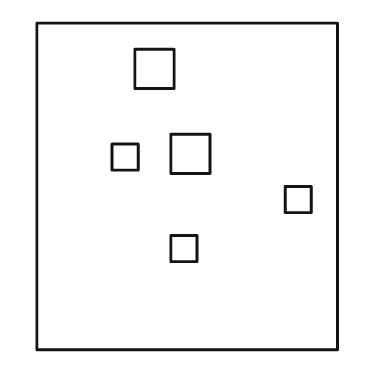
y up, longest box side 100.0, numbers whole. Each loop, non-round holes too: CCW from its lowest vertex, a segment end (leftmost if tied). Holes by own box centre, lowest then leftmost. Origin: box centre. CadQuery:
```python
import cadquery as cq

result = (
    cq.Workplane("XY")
    .moveTo(-46.0, -50.0)
    .lineTo(46.0, -50.0)
    .lineTo(46.0, 50.0)
    .lineTo(-46.0, 50.0)
    .close()
    .moveTo(-5.0, -23.0)
    .lineTo(3.0, -23.0)
    .lineTo(3.0, -15.0)
    .lineTo(-5.0, -15.0)
    .close()
    .moveTo(30.0, -8.0)
    .lineTo(38.0, -8.0)
    .lineTo(38.0, 0.0)
    .lineTo(30.0, 0.0)
    .close()
    .moveTo(-23.0, 5.0)
    .lineTo(-15.0, 5.0)
    .lineTo(-15.0, 13.0)
    .lineTo(-23.0, 13.0)
    .close()
    .moveTo(-5.0, 4.0)
    .lineTo(7.0, 4.0)
    .lineTo(7.0, 16.0)
    .lineTo(-5.0, 16.0)
    .close()
    .moveTo(-16.0, 30.0)
    .lineTo(-4.0, 30.0)
    .lineTo(-4.0, 42.0)
    .lineTo(-16.0, 42.0)
    .close()
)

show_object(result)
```